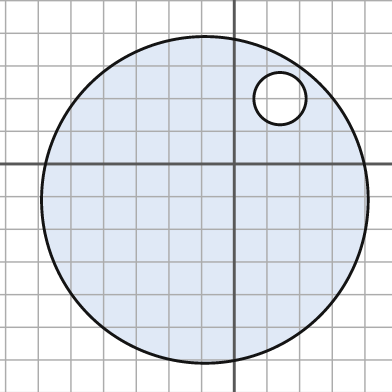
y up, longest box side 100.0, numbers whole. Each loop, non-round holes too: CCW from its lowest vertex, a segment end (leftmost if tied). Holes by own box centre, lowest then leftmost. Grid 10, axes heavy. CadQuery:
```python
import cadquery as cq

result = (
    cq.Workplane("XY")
    .moveTo(-9.0, -11.0)
    .circle(50.0)
    .moveTo(14.0, 20.0)
    .circle(8.0)
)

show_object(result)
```